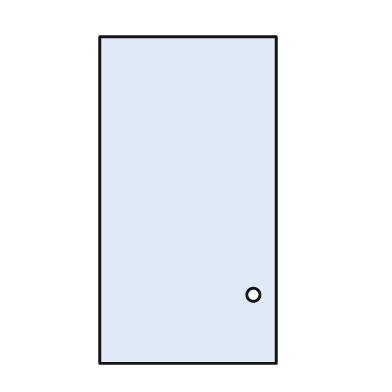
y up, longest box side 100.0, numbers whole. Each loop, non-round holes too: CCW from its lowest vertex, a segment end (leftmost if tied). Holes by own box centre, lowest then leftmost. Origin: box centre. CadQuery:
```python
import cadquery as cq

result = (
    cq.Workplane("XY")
    .moveTo(-27.0, -50.0)
    .lineTo(27.0, -50.0)
    .lineTo(27.0, 50.0)
    .lineTo(-27.0, 50.0)
    .close()
    .moveTo(20.0, -29.0)
    .circle(2.0)
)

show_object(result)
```